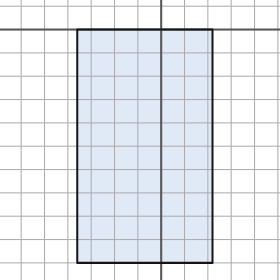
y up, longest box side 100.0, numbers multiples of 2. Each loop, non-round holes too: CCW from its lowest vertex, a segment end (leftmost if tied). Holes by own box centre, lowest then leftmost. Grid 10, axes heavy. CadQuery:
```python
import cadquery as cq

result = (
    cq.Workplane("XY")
    .moveTo(-36.0, -100.0)
    .lineTo(22.0, -100.0)
    .lineTo(22.0, 0.0)
    .lineTo(-36.0, 0.0)
    .close()
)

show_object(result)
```